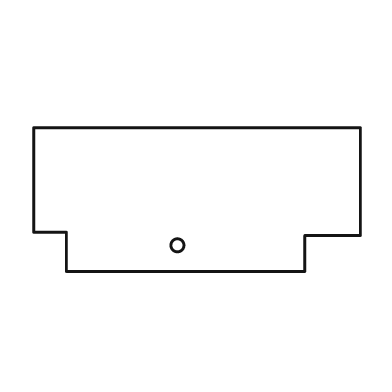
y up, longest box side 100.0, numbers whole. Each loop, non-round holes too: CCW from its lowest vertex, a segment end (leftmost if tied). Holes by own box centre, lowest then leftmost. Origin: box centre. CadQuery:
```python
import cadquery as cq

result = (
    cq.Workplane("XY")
    .moveTo(-40.0, -22.0)
    .lineTo(33.0, -22.0)
    .lineTo(33.0, -11.0)
    .lineTo(50.0, -11.0)
    .lineTo(50.0, 22.0)
    .lineTo(-50.0, 22.0)
    .lineTo(-50.0, -10.0)
    .lineTo(-40.0, -10.0)
    .close()
    .moveTo(-6.0, -14.0)
    .circle(2.0)
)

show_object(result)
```